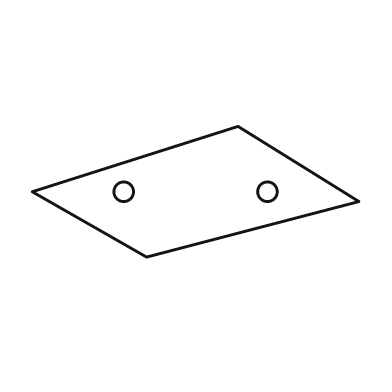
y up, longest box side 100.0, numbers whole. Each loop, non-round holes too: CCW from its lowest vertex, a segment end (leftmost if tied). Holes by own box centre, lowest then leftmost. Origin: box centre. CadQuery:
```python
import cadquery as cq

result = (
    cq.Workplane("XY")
    .moveTo(-15.0, -20.0)
    .lineTo(50.0, -3.0)
    .lineTo(13.0, 20.0)
    .lineTo(-50.0, 0.0)
    .close()
    .moveTo(-22.0, 0.0)
    .circle(3.0)
    .moveTo(22.0, 0.0)
    .circle(3.0)
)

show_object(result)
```